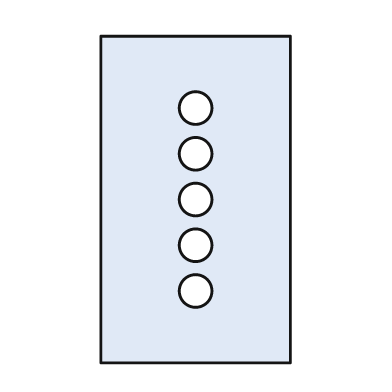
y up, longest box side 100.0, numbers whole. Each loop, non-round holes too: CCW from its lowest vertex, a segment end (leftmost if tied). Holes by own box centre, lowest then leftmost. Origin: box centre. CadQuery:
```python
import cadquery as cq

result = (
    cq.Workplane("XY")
    .moveTo(-29.0, -50.0)
    .lineTo(29.0, -50.0)
    .lineTo(29.0, 50.0)
    .lineTo(-29.0, 50.0)
    .close()
    .moveTo(0.0, -28.0)
    .circle(5.0)
    .moveTo(0.0, -14.0)
    .circle(5.0)
    .moveTo(0.0, 0.0)
    .circle(5.0)
    .moveTo(0.0, 14.0)
    .circle(5.0)
    .moveTo(0.0, 28.0)
    .circle(5.0)
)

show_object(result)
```